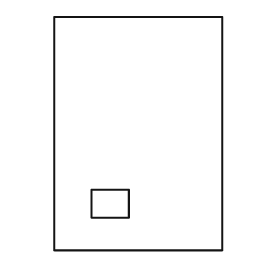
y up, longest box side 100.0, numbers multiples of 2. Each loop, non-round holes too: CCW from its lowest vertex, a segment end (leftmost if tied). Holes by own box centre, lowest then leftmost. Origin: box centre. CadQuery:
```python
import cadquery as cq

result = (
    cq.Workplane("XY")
    .moveTo(-36.0, -50.0)
    .lineTo(36.0, -50.0)
    .lineTo(36.0, 50.0)
    .lineTo(-36.0, 50.0)
    .close()
    .moveTo(-20.0, -36.0)
    .lineTo(-4.0, -36.0)
    .lineTo(-4.0, -24.0)
    .lineTo(-20.0, -24.0)
    .close()
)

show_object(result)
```